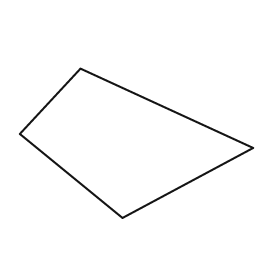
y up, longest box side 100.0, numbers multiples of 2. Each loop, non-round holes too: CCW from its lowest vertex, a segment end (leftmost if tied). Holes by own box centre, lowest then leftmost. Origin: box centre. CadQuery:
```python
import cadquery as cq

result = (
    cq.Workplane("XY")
    .moveTo(-6.0, -32.0)
    .lineTo(50.0, -2.0)
    .lineTo(-24.0, 32.0)
    .lineTo(-50.0, 4.0)
    .close()
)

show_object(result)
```